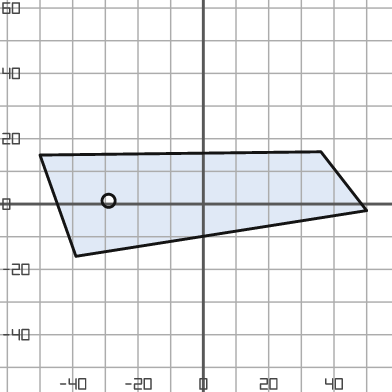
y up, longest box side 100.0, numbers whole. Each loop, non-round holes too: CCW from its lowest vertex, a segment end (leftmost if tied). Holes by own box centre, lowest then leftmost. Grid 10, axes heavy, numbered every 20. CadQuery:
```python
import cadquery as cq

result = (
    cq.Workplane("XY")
    .moveTo(-39.0, -16.0)
    .lineTo(50.0, -2.0)
    .lineTo(36.0, 16.0)
    .lineTo(-50.0, 15.0)
    .close()
    .moveTo(-29.0, 1.0)
    .circle(2.0)
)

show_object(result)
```